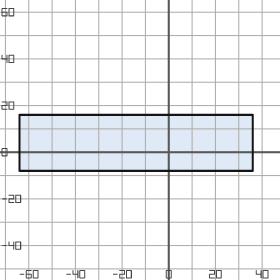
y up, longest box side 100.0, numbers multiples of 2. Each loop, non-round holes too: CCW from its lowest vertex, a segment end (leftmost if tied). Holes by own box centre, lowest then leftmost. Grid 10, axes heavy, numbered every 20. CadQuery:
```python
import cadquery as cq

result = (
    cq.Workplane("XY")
    .moveTo(-64.0, -8.0)
    .lineTo(36.0, -8.0)
    .lineTo(36.0, 16.0)
    .lineTo(-64.0, 16.0)
    .close()
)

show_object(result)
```